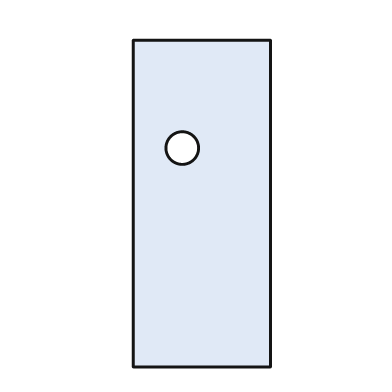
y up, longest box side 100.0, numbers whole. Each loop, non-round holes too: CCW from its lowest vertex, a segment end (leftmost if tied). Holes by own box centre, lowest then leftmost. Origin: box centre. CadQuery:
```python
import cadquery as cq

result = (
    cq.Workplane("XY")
    .moveTo(-21.0, -50.0)
    .lineTo(21.0, -50.0)
    .lineTo(21.0, 50.0)
    .lineTo(-21.0, 50.0)
    .close()
    .moveTo(-6.0, 17.0)
    .circle(5.0)
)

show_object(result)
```